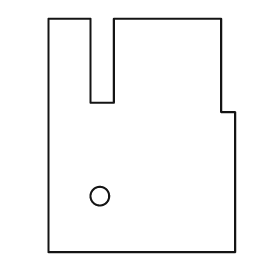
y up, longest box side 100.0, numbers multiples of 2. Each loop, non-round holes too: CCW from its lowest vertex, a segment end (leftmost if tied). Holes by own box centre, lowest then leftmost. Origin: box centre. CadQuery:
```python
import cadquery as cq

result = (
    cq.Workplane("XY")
    .moveTo(-40.0, -50.0)
    .lineTo(40.0, -50.0)
    .lineTo(40.0, 10.0)
    .lineTo(34.0, 10.0)
    .lineTo(34.0, 50.0)
    .lineTo(-12.0, 50.0)
    .lineTo(-12.0, 14.0)
    .lineTo(-22.0, 14.0)
    .lineTo(-22.0, 50.0)
    .lineTo(-40.0, 50.0)
    .close()
    .moveTo(-18.0, -26.0)
    .circle(4.0)
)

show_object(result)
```